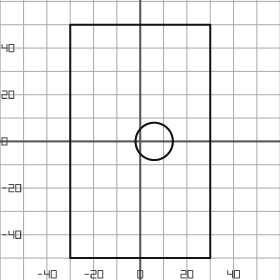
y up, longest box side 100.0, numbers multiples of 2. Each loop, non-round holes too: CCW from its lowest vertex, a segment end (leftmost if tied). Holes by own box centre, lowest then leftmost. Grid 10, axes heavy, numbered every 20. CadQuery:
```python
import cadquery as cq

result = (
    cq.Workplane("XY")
    .moveTo(-30.0, -50.0)
    .lineTo(30.0, -50.0)
    .lineTo(30.0, 50.0)
    .lineTo(-30.0, 50.0)
    .close()
    .moveTo(6.0, 0.0)
    .circle(8.0)
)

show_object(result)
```